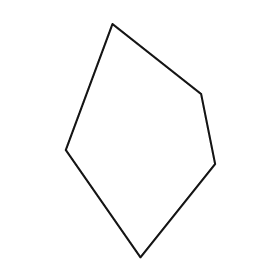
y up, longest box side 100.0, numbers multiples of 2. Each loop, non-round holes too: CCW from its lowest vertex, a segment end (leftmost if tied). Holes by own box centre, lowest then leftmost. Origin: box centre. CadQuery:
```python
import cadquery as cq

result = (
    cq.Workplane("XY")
    .moveTo(0.0, -50.0)
    .lineTo(32.0, -10.0)
    .lineTo(26.0, 20.0)
    .lineTo(-12.0, 50.0)
    .lineTo(-32.0, -4.0)
    .close()
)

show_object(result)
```